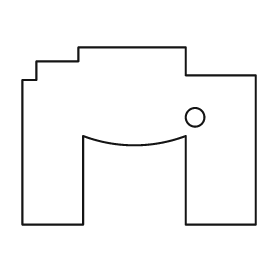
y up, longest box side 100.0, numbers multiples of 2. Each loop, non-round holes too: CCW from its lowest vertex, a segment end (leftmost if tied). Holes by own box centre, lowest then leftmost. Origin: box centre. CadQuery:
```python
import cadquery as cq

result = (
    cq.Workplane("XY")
    .moveTo(-50.0, -38.0)
    .lineTo(-24.0, -38.0)
    .lineTo(-24.0, 0.0)
    .threePointArc((-2.0, -4.0), (20.0, 0.0))
    .lineTo(20.0, -38.0)
    .lineTo(50.0, -38.0)
    .lineTo(50.0, 26.0)
    .lineTo(20.0, 26.0)
    .lineTo(20.0, 38.0)
    .lineTo(-26.0, 38.0)
    .lineTo(-26.0, 32.0)
    .lineTo(-44.0, 32.0)
    .lineTo(-44.0, 24.0)
    .lineTo(-50.0, 24.0)
    .close()
    .moveTo(24.0, 8.0)
    .circle(4.0)
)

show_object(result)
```